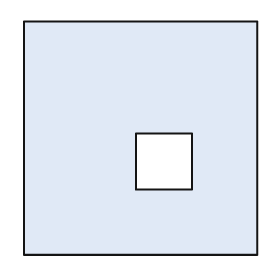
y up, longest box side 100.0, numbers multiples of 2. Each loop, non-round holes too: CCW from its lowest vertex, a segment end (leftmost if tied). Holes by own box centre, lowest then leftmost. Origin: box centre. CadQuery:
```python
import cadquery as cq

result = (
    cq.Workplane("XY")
    .moveTo(-50.0, -50.0)
    .lineTo(50.0, -50.0)
    .lineTo(50.0, 50.0)
    .lineTo(-50.0, 50.0)
    .close()
    .moveTo(-2.0, -22.0)
    .lineTo(22.0, -22.0)
    .lineTo(22.0, 2.0)
    .lineTo(-2.0, 2.0)
    .close()
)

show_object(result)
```